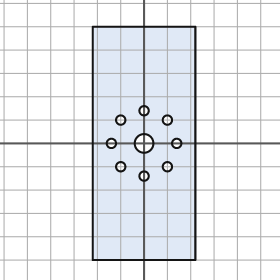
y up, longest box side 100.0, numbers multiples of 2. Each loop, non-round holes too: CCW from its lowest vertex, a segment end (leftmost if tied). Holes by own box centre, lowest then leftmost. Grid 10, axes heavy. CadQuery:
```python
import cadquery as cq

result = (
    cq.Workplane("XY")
    .moveTo(-22.0, -50.0)
    .lineTo(22.0, -50.0)
    .lineTo(22.0, 50.0)
    .lineTo(-22.0, 50.0)
    .close()
    .moveTo(0.0, -14.0)
    .circle(2.0)
    .moveTo(-10.0, -10.0)
    .circle(2.0)
    .moveTo(10.0, -10.0)
    .circle(2.0)
    .moveTo(-14.0, 0.0)
    .circle(2.0)
    .moveTo(0.0, 0.0)
    .circle(4.0)
    .moveTo(14.0, 0.0)
    .circle(2.0)
    .moveTo(-10.0, 10.0)
    .circle(2.0)
    .moveTo(10.0, 10.0)
    .circle(2.0)
    .moveTo(0.0, 14.0)
    .circle(2.0)
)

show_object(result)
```